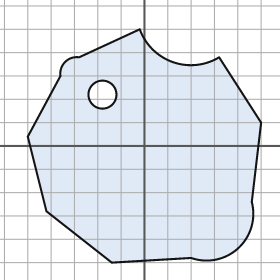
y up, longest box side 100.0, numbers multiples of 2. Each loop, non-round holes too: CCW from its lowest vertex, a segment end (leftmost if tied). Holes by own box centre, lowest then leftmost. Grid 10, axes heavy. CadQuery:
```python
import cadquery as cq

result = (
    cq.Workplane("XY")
    .moveTo(-14.0, -50.0)
    .lineTo(20.0, -48.0)
    .threePointArc((40.0, -44.0), (46.0, -24.0))
    .lineTo(50.0, 10.0)
    .lineTo(32.0, 38.0)
    .threePointArc((12.0, 36.0), (-2.0, 50.0))
    .lineTo(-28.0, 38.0)
    .threePointArc((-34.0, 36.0), (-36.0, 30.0))
    .lineTo(-50.0, 4.0)
    .lineTo(-42.0, -28.0)
    .close()
    .moveTo(-18.0, 22.0)
    .circle(6.0)
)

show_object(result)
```